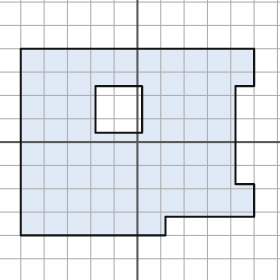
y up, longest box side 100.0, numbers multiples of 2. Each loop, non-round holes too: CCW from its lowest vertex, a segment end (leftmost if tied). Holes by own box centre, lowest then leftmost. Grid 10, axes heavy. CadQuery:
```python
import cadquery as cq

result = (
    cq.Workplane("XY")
    .moveTo(-50.0, -40.0)
    .lineTo(12.0, -40.0)
    .lineTo(12.0, -32.0)
    .lineTo(50.0, -32.0)
    .lineTo(50.0, -18.0)
    .lineTo(42.0, -18.0)
    .lineTo(42.0, 24.0)
    .lineTo(50.0, 24.0)
    .lineTo(50.0, 40.0)
    .lineTo(-50.0, 40.0)
    .close()
    .moveTo(-18.0, 4.0)
    .lineTo(2.0, 4.0)
    .lineTo(2.0, 24.0)
    .lineTo(-18.0, 24.0)
    .close()
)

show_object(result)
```